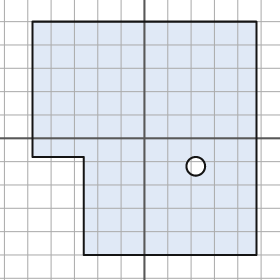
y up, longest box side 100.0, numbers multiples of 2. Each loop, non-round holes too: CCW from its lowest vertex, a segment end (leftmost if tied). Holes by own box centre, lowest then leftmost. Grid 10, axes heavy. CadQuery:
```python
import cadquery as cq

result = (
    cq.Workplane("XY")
    .moveTo(-26.0, -50.0)
    .lineTo(48.0, -50.0)
    .lineTo(48.0, 50.0)
    .lineTo(-48.0, 50.0)
    .lineTo(-48.0, -8.0)
    .lineTo(-26.0, -8.0)
    .close()
    .moveTo(22.0, -12.0)
    .circle(4.0)
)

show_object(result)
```